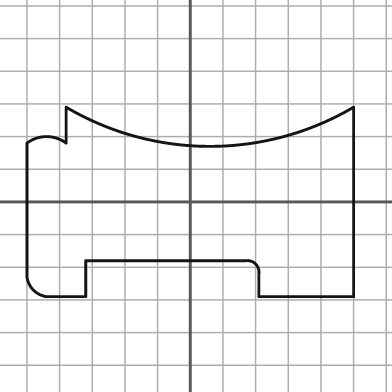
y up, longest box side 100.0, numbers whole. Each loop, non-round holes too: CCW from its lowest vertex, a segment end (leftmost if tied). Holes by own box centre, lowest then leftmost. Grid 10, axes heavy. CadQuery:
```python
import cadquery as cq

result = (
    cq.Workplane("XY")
    .moveTo(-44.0, -29.0)
    .lineTo(-32.0, -29.0)
    .lineTo(-32.0, -18.0)
    .lineTo(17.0, -18.0)
    .threePointArc((20.0, -19.0), (21.0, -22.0))
    .lineTo(21.0, -29.0)
    .lineTo(50.0, -29.0)
    .lineTo(50.0, 29.0)
    .threePointArc((6.0, 17.0), (-38.0, 29.0))
    .lineTo(-38.0, 18.0)
    .threePointArc((-44.0, 20.0), (-50.0, 18.0))
    .lineTo(-50.0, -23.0)
    .threePointArc((-48.0, -27.0), (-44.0, -29.0))
    .close()
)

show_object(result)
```